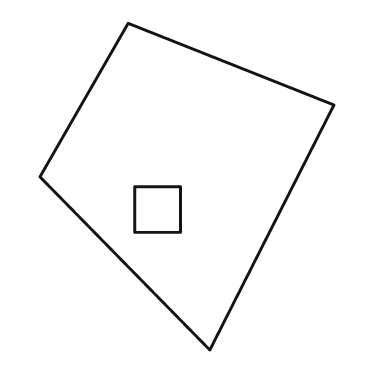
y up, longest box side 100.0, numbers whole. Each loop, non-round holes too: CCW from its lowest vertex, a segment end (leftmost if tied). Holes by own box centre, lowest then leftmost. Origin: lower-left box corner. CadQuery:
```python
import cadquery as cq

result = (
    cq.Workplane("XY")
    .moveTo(52.0, 0.0)
    .lineTo(90.0, 75.0)
    .lineTo(27.0, 100.0)
    .lineTo(0.0, 53.0)
    .close()
    .moveTo(29.0, 36.0)
    .lineTo(43.0, 36.0)
    .lineTo(43.0, 50.0)
    .lineTo(29.0, 50.0)
    .close()
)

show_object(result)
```